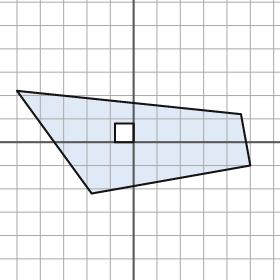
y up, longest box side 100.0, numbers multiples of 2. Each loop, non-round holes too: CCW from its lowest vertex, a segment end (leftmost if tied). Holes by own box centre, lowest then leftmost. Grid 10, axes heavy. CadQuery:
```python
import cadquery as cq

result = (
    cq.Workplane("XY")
    .moveTo(-18.0, -22.0)
    .lineTo(50.0, -10.0)
    .lineTo(46.0, 12.0)
    .lineTo(-50.0, 22.0)
    .close()
    .moveTo(-8.0, 0.0)
    .lineTo(0.0, 0.0)
    .lineTo(0.0, 8.0)
    .lineTo(-8.0, 8.0)
    .close()
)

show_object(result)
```